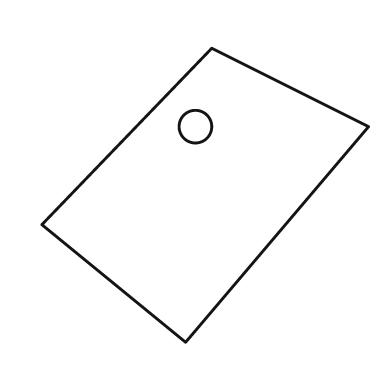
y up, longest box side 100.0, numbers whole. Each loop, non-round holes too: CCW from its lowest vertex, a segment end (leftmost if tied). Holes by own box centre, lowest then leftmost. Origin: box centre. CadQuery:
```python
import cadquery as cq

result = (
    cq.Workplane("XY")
    .moveTo(-6.0, -45.0)
    .lineTo(50.0, 21.0)
    .lineTo(2.0, 45.0)
    .lineTo(-50.0, -9.0)
    .close()
    .moveTo(-3.0, 21.0)
    .circle(5.0)
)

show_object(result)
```